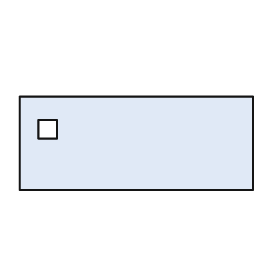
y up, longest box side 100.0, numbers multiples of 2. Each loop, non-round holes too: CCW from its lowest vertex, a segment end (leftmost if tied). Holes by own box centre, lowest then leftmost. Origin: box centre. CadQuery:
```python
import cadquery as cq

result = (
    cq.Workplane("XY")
    .moveTo(-50.0, -20.0)
    .lineTo(50.0, -20.0)
    .lineTo(50.0, 20.0)
    .lineTo(-50.0, 20.0)
    .close()
    .moveTo(-42.0, 2.0)
    .lineTo(-34.0, 2.0)
    .lineTo(-34.0, 10.0)
    .lineTo(-42.0, 10.0)
    .close()
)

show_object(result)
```